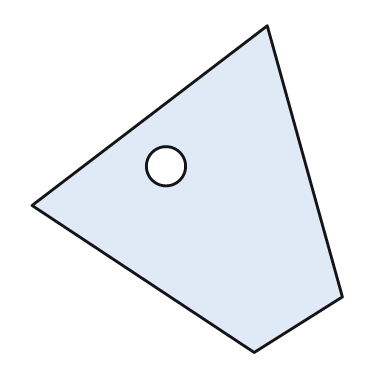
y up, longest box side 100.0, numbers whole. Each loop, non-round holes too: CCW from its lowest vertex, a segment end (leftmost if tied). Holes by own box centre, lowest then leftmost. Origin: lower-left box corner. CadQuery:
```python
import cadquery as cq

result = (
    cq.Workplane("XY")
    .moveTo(68.0, 0.0)
    .lineTo(95.0, 17.0)
    .lineTo(72.0, 100.0)
    .lineTo(0.0, 45.0)
    .close()
    .moveTo(41.0, 57.0)
    .circle(6.0)
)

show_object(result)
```